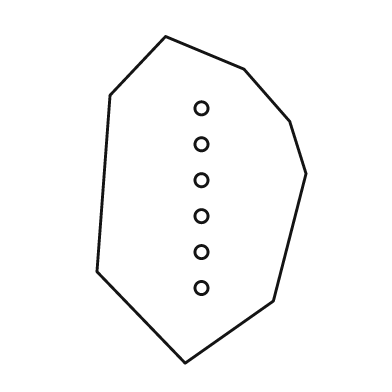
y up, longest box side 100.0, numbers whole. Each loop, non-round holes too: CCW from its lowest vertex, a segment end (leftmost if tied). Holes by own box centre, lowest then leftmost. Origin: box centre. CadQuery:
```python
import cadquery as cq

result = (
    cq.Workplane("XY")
    .moveTo(-5.0, -50.0)
    .lineTo(22.0, -31.0)
    .lineTo(32.0, 8.0)
    .lineTo(27.0, 24.0)
    .lineTo(13.0, 40.0)
    .lineTo(-11.0, 50.0)
    .lineTo(-28.0, 32.0)
    .lineTo(-32.0, -22.0)
    .close()
    .moveTo(0.0, -27.0)
    .circle(2.0)
    .moveTo(0.0, -16.0)
    .circle(2.0)
    .moveTo(0.0, -5.0)
    .circle(2.0)
    .moveTo(0.0, 6.0)
    .circle(2.0)
    .moveTo(0.0, 17.0)
    .circle(2.0)
    .moveTo(0.0, 28.0)
    .circle(2.0)
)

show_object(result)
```